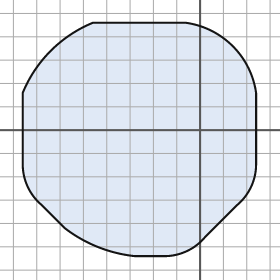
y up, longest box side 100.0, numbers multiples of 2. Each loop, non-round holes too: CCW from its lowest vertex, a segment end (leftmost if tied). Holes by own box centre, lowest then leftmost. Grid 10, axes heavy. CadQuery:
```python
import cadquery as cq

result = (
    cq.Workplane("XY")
    .moveTo(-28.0, -54.0)
    .lineTo(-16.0, -54.0)
    .threePointArc((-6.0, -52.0), (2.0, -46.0))
    .lineTo(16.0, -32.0)
    .threePointArc((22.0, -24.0), (24.0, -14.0))
    .lineTo(24.0, 16.0)
    .threePointArc((14.0, 36.0), (-6.0, 46.0))
    .lineTo(-46.0, 46.0)
    .threePointArc((-64.0, 34.0), (-76.0, 16.0))
    .lineTo(-76.0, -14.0)
    .threePointArc((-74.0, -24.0), (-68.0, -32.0))
    .lineTo(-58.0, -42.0)
    .threePointArc((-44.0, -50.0), (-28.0, -54.0))
    .close()
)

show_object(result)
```